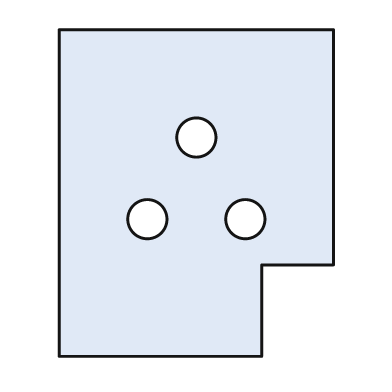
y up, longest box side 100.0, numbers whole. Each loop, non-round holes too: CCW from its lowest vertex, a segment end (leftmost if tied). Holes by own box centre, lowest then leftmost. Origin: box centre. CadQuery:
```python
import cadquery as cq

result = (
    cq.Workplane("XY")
    .moveTo(-42.0, -50.0)
    .lineTo(20.0, -50.0)
    .lineTo(20.0, -22.0)
    .lineTo(42.0, -22.0)
    .lineTo(42.0, 50.0)
    .lineTo(-42.0, 50.0)
    .close()
    .moveTo(-15.0, -8.0)
    .circle(6.0)
    .moveTo(15.0, -8.0)
    .circle(6.0)
    .moveTo(0.0, 17.0)
    .circle(6.0)
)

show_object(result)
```